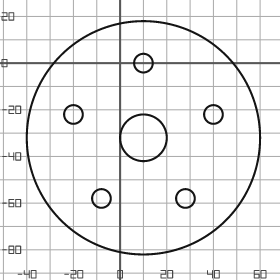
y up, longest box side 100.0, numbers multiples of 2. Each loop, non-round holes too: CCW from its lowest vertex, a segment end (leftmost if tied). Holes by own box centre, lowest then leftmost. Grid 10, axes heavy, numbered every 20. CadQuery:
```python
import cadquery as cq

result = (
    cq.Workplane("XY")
    .moveTo(10.0, -32.0)
    .circle(50.0)
    .moveTo(-8.0, -58.0)
    .circle(4.0)
    .moveTo(28.0, -58.0)
    .circle(4.0)
    .moveTo(10.0, -32.0)
    .circle(10.0)
    .moveTo(-20.0, -22.0)
    .circle(4.0)
    .moveTo(40.0, -22.0)
    .circle(4.0)
    .moveTo(10.0, 0.0)
    .circle(4.0)
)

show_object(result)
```